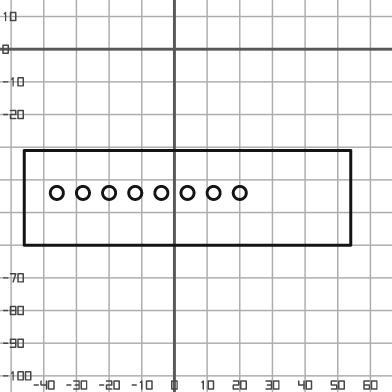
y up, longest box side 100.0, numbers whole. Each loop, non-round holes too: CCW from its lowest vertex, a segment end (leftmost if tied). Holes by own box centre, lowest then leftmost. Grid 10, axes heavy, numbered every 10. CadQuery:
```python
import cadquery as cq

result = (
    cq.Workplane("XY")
    .moveTo(-46.0, -60.0)
    .lineTo(54.0, -60.0)
    .lineTo(54.0, -31.0)
    .lineTo(-46.0, -31.0)
    .close()
    .moveTo(-36.0, -44.0)
    .circle(2.0)
    .moveTo(-28.0, -44.0)
    .circle(2.0)
    .moveTo(-20.0, -44.0)
    .circle(2.0)
    .moveTo(-12.0, -44.0)
    .circle(2.0)
    .moveTo(-4.0, -44.0)
    .circle(2.0)
    .moveTo(4.0, -44.0)
    .circle(2.0)
    .moveTo(12.0, -44.0)
    .circle(2.0)
    .moveTo(20.0, -44.0)
    .circle(2.0)
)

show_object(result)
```